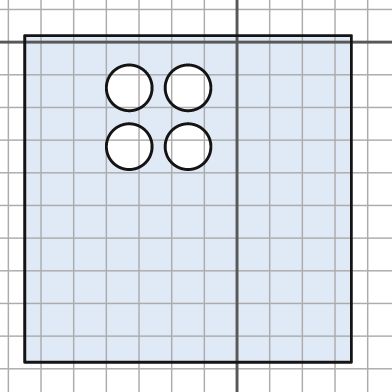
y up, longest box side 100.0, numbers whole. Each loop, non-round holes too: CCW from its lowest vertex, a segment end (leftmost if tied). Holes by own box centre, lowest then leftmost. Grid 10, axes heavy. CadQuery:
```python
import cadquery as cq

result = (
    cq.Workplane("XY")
    .moveTo(-65.0, -98.0)
    .lineTo(35.0, -98.0)
    .lineTo(35.0, 2.0)
    .lineTo(-65.0, 2.0)
    .close()
    .moveTo(-33.0, -32.0)
    .circle(7.0)
    .moveTo(-15.0, -32.0)
    .circle(7.0)
    .moveTo(-33.0, -14.0)
    .circle(7.0)
    .moveTo(-15.0, -14.0)
    .circle(7.0)
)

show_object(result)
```